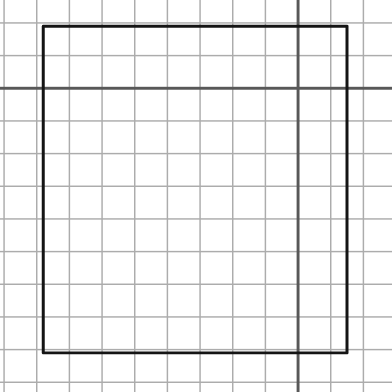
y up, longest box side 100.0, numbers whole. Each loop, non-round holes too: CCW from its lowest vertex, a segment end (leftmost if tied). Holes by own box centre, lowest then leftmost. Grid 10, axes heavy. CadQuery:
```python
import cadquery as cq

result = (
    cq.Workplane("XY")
    .moveTo(-78.0, -81.0)
    .lineTo(15.0, -81.0)
    .lineTo(15.0, 19.0)
    .lineTo(-78.0, 19.0)
    .close()
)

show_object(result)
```